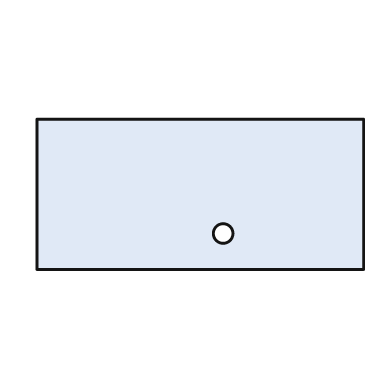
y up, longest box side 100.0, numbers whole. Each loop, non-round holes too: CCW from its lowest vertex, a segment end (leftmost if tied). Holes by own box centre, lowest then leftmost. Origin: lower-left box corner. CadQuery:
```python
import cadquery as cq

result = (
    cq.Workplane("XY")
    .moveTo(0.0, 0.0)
    .lineTo(100.0, 0.0)
    .lineTo(100.0, 46.0)
    .lineTo(0.0, 46.0)
    .close()
    .moveTo(57.0, 11.0)
    .circle(3.0)
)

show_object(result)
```